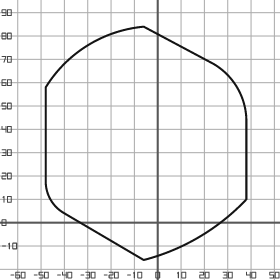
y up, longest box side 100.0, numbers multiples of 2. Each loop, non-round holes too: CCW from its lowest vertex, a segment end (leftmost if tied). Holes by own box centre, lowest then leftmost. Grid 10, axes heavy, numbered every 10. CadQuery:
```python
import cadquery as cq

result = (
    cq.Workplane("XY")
    .moveTo(-6.0, -16.0)
    .threePointArc((18.0, -6.0), (38.0, 10.0))
    .lineTo(38.0, 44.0)
    .threePointArc((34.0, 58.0), (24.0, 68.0))
    .lineTo(-6.0, 84.0)
    .threePointArc((-30.0, 76.0), (-48.0, 58.0))
    .lineTo(-48.0, 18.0)
    .threePointArc((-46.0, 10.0), (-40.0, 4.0))
    .close()
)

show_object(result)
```